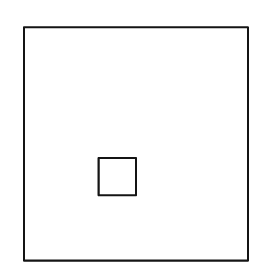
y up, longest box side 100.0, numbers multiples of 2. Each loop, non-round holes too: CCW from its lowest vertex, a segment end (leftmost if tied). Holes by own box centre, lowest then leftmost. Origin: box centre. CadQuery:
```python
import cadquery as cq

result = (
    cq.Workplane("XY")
    .moveTo(-48.0, -50.0)
    .lineTo(48.0, -50.0)
    .lineTo(48.0, 50.0)
    .lineTo(-48.0, 50.0)
    .close()
    .moveTo(-16.0, -22.0)
    .lineTo(0.0, -22.0)
    .lineTo(0.0, -6.0)
    .lineTo(-16.0, -6.0)
    .close()
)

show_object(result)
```